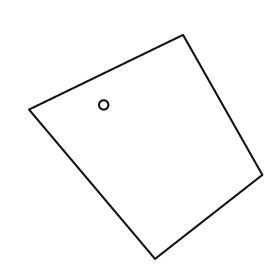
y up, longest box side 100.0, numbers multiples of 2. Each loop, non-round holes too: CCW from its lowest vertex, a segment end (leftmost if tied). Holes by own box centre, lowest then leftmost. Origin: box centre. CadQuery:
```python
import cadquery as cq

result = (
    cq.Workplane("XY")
    .moveTo(4.0, -48.0)
    .lineTo(50.0, -12.0)
    .lineTo(16.0, 48.0)
    .lineTo(-50.0, 16.0)
    .close()
    .moveTo(-18.0, 18.0)
    .circle(2.0)
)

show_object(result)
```